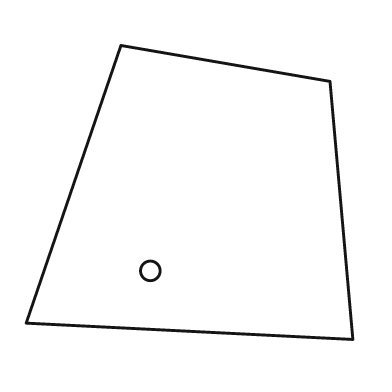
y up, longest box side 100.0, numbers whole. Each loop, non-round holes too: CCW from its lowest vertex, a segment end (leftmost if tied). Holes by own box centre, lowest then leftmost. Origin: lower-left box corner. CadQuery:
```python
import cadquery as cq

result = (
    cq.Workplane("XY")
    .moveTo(100.0, 0.0)
    .lineTo(93.0, 79.0)
    .lineTo(29.0, 90.0)
    .lineTo(0.0, 5.0)
    .close()
    .moveTo(38.0, 21.0)
    .circle(3.0)
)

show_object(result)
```